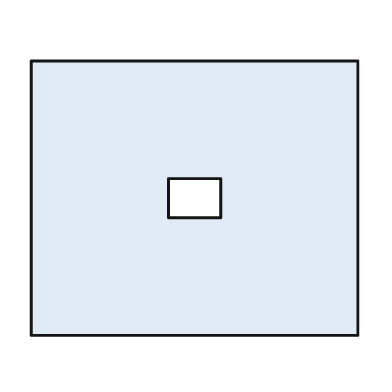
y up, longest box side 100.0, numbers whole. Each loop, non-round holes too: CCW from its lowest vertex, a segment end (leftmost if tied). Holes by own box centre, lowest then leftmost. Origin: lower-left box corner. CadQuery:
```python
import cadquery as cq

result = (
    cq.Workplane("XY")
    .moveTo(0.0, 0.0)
    .lineTo(100.0, 0.0)
    .lineTo(100.0, 84.0)
    .lineTo(0.0, 84.0)
    .close()
    .moveTo(42.0, 36.0)
    .lineTo(58.0, 36.0)
    .lineTo(58.0, 48.0)
    .lineTo(42.0, 48.0)
    .close()
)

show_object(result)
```